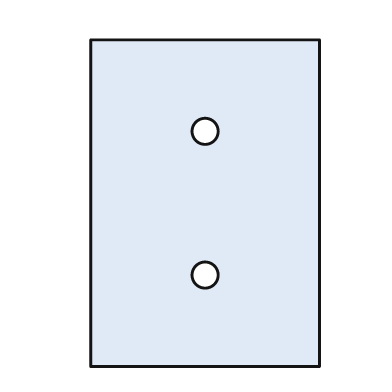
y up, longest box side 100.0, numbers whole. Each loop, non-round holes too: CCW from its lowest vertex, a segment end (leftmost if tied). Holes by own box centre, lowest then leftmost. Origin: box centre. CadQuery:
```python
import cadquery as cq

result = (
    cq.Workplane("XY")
    .moveTo(-35.0, -50.0)
    .lineTo(35.0, -50.0)
    .lineTo(35.0, 50.0)
    .lineTo(-35.0, 50.0)
    .close()
    .moveTo(0.0, -22.0)
    .circle(4.0)
    .moveTo(0.0, 22.0)
    .circle(4.0)
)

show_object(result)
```